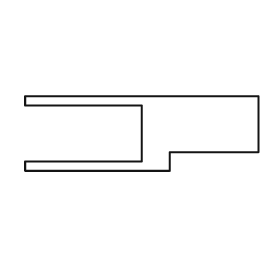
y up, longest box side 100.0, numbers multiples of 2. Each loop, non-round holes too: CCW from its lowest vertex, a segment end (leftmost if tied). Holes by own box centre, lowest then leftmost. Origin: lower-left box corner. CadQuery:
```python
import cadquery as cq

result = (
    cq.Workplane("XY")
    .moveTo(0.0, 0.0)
    .lineTo(62.0, 0.0)
    .lineTo(62.0, 8.0)
    .lineTo(100.0, 8.0)
    .lineTo(100.0, 32.0)
    .lineTo(0.0, 32.0)
    .lineTo(0.0, 28.0)
    .lineTo(50.0, 28.0)
    .lineTo(50.0, 4.0)
    .lineTo(0.0, 4.0)
    .close()
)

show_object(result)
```